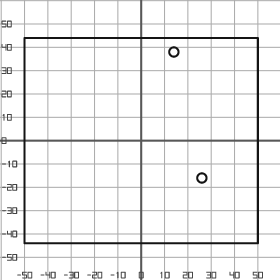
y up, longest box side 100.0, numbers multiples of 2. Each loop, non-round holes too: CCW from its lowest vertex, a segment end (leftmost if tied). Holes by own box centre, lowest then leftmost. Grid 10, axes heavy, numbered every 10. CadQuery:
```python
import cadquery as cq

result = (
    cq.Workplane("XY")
    .moveTo(-50.0, -44.0)
    .lineTo(50.0, -44.0)
    .lineTo(50.0, 44.0)
    .lineTo(-50.0, 44.0)
    .close()
    .moveTo(26.0, -16.0)
    .circle(2.0)
    .moveTo(14.0, 38.0)
    .circle(2.0)
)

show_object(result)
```